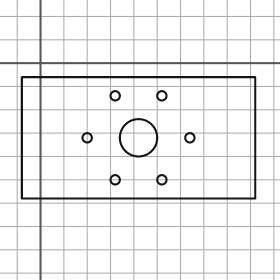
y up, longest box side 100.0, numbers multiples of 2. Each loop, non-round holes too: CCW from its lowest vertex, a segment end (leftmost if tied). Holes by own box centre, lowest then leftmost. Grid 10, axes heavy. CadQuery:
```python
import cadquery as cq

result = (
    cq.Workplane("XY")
    .moveTo(-8.0, -58.0)
    .lineTo(92.0, -58.0)
    .lineTo(92.0, -6.0)
    .lineTo(-8.0, -6.0)
    .close()
    .moveTo(32.0, -50.0)
    .circle(2.0)
    .moveTo(52.0, -50.0)
    .circle(2.0)
    .moveTo(20.0, -32.0)
    .circle(2.0)
    .moveTo(42.0, -32.0)
    .circle(8.0)
    .moveTo(64.0, -32.0)
    .circle(2.0)
    .moveTo(32.0, -14.0)
    .circle(2.0)
    .moveTo(52.0, -14.0)
    .circle(2.0)
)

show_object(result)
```